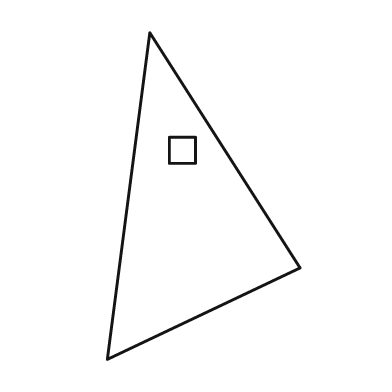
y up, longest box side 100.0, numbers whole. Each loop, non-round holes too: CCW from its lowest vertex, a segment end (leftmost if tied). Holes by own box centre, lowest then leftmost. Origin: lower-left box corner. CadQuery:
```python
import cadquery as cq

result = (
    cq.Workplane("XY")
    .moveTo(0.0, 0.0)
    .lineTo(59.0, 28.0)
    .lineTo(13.0, 100.0)
    .close()
    .moveTo(19.0, 60.0)
    .lineTo(27.0, 60.0)
    .lineTo(27.0, 68.0)
    .lineTo(19.0, 68.0)
    .close()
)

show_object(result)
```